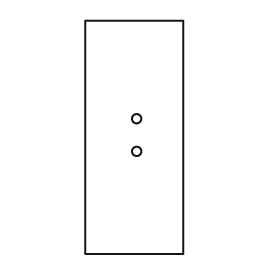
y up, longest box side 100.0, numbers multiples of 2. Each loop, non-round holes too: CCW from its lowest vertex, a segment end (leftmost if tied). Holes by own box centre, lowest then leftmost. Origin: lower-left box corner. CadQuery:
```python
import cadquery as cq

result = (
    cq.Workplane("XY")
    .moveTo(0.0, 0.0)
    .lineTo(42.0, 0.0)
    .lineTo(42.0, 100.0)
    .lineTo(0.0, 100.0)
    .close()
    .moveTo(22.0, 44.0)
    .circle(2.0)
    .moveTo(22.0, 58.0)
    .circle(2.0)
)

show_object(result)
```